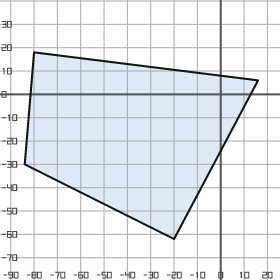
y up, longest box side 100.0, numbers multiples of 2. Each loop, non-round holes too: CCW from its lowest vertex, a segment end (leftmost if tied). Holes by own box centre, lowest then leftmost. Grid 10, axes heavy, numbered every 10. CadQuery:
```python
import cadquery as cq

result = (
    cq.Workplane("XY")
    .moveTo(-20.0, -62.0)
    .lineTo(16.0, 6.0)
    .lineTo(-80.0, 18.0)
    .lineTo(-84.0, -30.0)
    .close()
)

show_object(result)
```